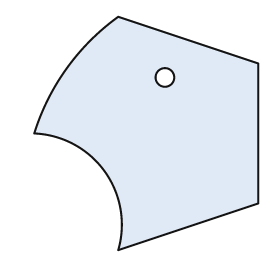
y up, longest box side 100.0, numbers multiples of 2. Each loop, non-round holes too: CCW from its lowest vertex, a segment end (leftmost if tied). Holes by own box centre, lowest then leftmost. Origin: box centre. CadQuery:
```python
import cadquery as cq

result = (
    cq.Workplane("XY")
    .moveTo(-12.0, -50.0)
    .lineTo(48.0, -30.0)
    .lineTo(48.0, 30.0)
    .lineTo(-12.0, 50.0)
    .threePointArc((-34.0, 28.0), (-48.0, 0.0))
    .threePointArc((-18.0, -16.0), (-12.0, -50.0))
    .close()
    .moveTo(8.0, 24.0)
    .circle(4.0)
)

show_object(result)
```